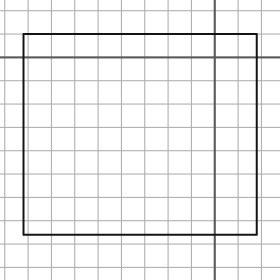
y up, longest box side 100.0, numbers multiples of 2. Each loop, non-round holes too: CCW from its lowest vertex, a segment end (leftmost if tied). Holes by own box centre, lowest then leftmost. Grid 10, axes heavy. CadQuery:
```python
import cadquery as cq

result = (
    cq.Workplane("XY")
    .moveTo(-82.0, -76.0)
    .lineTo(18.0, -76.0)
    .lineTo(18.0, 10.0)
    .lineTo(-82.0, 10.0)
    .close()
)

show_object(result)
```